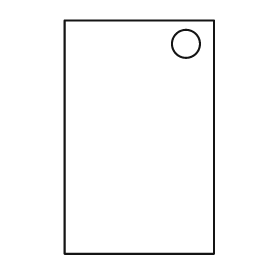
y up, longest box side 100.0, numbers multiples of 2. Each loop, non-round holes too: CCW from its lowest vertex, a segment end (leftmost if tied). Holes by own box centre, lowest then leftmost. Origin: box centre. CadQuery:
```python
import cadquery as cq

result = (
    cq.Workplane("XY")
    .moveTo(-32.0, -50.0)
    .lineTo(32.0, -50.0)
    .lineTo(32.0, 50.0)
    .lineTo(-32.0, 50.0)
    .close()
    .moveTo(20.0, 40.0)
    .circle(6.0)
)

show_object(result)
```